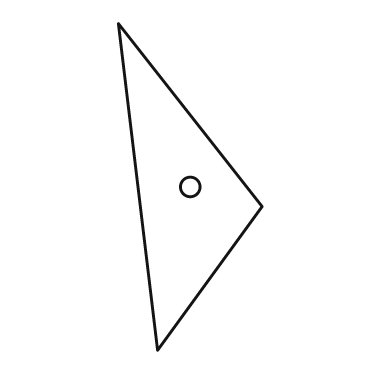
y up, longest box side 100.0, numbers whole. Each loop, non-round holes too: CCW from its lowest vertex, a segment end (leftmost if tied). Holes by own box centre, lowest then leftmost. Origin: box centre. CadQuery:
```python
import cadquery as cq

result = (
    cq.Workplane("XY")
    .moveTo(-10.0, -50.0)
    .lineTo(22.0, -6.0)
    .lineTo(-22.0, 50.0)
    .close()
    .moveTo(0.0, 0.0)
    .circle(3.0)
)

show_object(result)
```